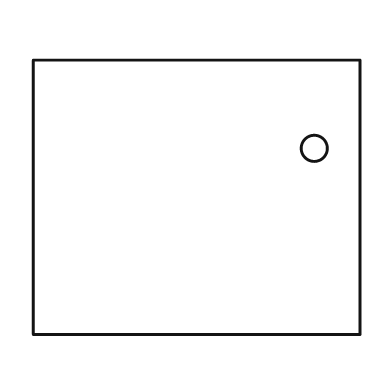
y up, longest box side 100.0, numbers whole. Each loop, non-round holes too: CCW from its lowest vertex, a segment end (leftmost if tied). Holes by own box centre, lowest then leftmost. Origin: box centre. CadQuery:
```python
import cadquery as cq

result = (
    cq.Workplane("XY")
    .moveTo(-50.0, -42.0)
    .lineTo(50.0, -42.0)
    .lineTo(50.0, 42.0)
    .lineTo(-50.0, 42.0)
    .close()
    .moveTo(36.0, 15.0)
    .circle(4.0)
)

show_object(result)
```